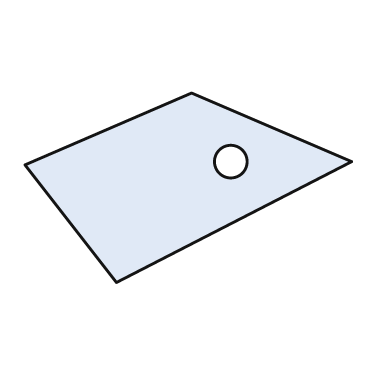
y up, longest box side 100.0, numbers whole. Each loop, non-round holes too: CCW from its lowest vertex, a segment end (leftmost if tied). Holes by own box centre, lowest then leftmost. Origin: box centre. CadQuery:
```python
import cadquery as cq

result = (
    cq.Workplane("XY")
    .moveTo(-22.0, -29.0)
    .lineTo(50.0, 8.0)
    .lineTo(1.0, 29.0)
    .lineTo(-50.0, 7.0)
    .close()
    .moveTo(13.0, 8.0)
    .circle(5.0)
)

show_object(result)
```